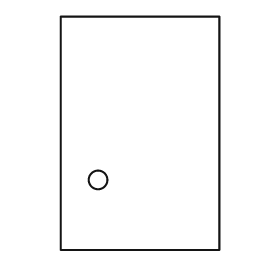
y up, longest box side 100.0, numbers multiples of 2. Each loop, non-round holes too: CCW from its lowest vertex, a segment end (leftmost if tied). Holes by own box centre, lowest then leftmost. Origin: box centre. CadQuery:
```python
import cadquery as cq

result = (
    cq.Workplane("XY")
    .moveTo(-34.0, -50.0)
    .lineTo(34.0, -50.0)
    .lineTo(34.0, 50.0)
    .lineTo(-34.0, 50.0)
    .close()
    .moveTo(-18.0, -20.0)
    .circle(4.0)
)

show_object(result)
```